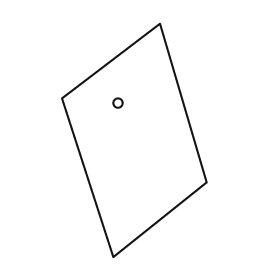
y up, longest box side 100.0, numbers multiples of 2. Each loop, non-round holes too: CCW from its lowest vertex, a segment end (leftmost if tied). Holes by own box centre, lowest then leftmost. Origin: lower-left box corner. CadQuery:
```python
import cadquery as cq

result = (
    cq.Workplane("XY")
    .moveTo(22.0, 0.0)
    .lineTo(62.0, 32.0)
    .lineTo(42.0, 100.0)
    .lineTo(0.0, 68.0)
    .close()
    .moveTo(24.0, 66.0)
    .circle(2.0)
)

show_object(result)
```